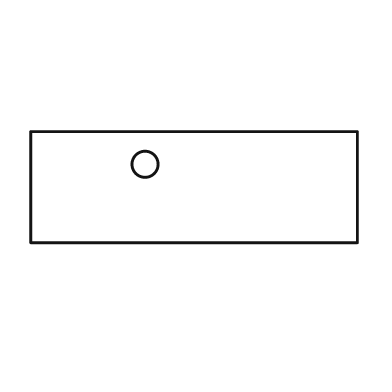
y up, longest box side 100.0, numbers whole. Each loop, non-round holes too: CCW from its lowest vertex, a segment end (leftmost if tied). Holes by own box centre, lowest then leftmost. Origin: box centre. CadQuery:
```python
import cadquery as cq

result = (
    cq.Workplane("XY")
    .moveTo(-50.0, -17.0)
    .lineTo(50.0, -17.0)
    .lineTo(50.0, 17.0)
    .lineTo(-50.0, 17.0)
    .close()
    .moveTo(-15.0, 7.0)
    .circle(4.0)
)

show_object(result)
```